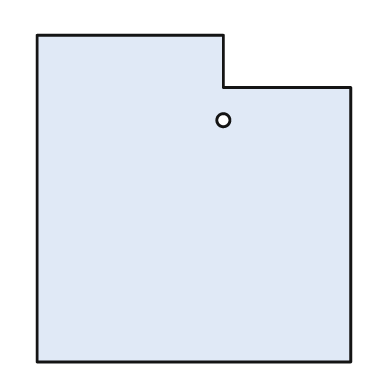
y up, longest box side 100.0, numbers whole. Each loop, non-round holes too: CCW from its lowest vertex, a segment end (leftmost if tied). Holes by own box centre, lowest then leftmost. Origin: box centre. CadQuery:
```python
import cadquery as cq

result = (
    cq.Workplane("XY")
    .moveTo(-48.0, -50.0)
    .lineTo(48.0, -50.0)
    .lineTo(48.0, 34.0)
    .lineTo(9.0, 34.0)
    .lineTo(9.0, 50.0)
    .lineTo(-48.0, 50.0)
    .close()
    .moveTo(9.0, 24.0)
    .circle(2.0)
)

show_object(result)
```